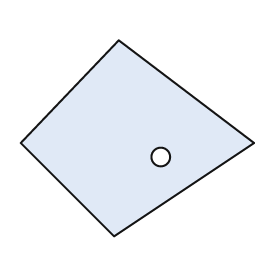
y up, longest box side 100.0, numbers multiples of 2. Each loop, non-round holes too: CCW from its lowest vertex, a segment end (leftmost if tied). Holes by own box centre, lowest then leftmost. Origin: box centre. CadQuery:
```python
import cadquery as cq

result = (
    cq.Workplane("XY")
    .moveTo(-10.0, -42.0)
    .lineTo(50.0, -2.0)
    .lineTo(-8.0, 42.0)
    .lineTo(-50.0, -2.0)
    .close()
    .moveTo(10.0, -8.0)
    .circle(4.0)
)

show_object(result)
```